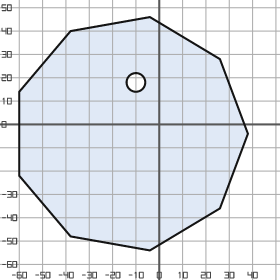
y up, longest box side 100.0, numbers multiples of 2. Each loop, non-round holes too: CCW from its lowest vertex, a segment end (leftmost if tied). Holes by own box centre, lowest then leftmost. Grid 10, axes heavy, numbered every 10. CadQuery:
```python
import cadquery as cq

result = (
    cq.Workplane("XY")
    .moveTo(-4.0, -54.0)
    .lineTo(26.0, -36.0)
    .lineTo(38.0, -4.0)
    .lineTo(26.0, 28.0)
    .lineTo(-4.0, 46.0)
    .lineTo(-38.0, 40.0)
    .lineTo(-60.0, 14.0)
    .lineTo(-60.0, -22.0)
    .lineTo(-38.0, -48.0)
    .close()
    .moveTo(-10.0, 18.0)
    .circle(4.0)
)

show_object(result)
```